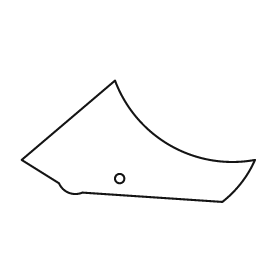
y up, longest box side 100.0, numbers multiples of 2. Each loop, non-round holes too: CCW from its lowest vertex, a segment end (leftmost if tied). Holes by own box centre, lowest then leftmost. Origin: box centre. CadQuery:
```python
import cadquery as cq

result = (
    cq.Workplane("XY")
    .moveTo(36.0, -26.0)
    .threePointArc((44.0, -18.0), (50.0, -8.0))
    .threePointArc((14.0, -2.0), (-10.0, 26.0))
    .lineTo(-50.0, -8.0)
    .lineTo(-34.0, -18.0)
    .threePointArc((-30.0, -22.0), (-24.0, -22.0))
    .close()
    .moveTo(-8.0, -16.0)
    .circle(2.0)
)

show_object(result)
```